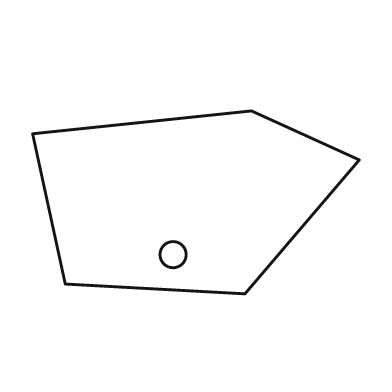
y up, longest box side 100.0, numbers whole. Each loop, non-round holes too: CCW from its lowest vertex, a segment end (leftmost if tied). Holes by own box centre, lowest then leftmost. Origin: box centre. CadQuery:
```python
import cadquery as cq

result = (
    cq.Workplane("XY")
    .moveTo(15.0, -28.0)
    .lineTo(50.0, 13.0)
    .lineTo(17.0, 28.0)
    .lineTo(-50.0, 21.0)
    .lineTo(-40.0, -25.0)
    .close()
    .moveTo(-7.0, -16.0)
    .circle(4.0)
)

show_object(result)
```